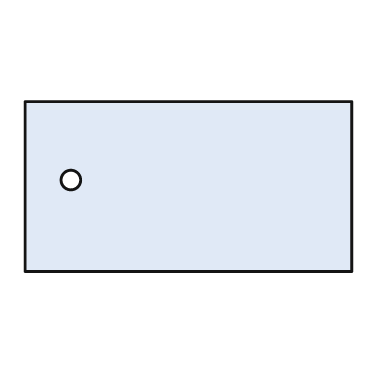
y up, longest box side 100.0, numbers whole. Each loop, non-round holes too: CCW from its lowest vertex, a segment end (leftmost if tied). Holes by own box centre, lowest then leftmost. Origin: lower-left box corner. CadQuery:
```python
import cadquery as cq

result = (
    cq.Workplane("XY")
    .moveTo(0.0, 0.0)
    .lineTo(100.0, 0.0)
    .lineTo(100.0, 52.0)
    .lineTo(0.0, 52.0)
    .close()
    .moveTo(14.0, 28.0)
    .circle(3.0)
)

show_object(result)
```